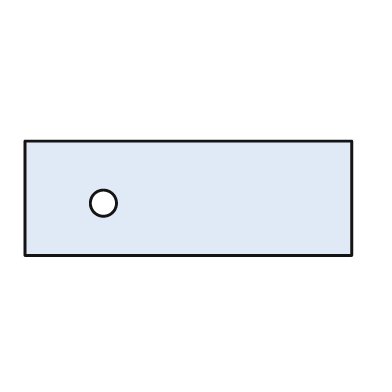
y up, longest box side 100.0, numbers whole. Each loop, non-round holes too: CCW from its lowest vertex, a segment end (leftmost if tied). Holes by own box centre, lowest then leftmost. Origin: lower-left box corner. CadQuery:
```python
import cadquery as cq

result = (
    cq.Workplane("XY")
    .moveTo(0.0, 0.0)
    .lineTo(100.0, 0.0)
    .lineTo(100.0, 35.0)
    .lineTo(0.0, 35.0)
    .close()
    .moveTo(24.0, 16.0)
    .circle(4.0)
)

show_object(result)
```